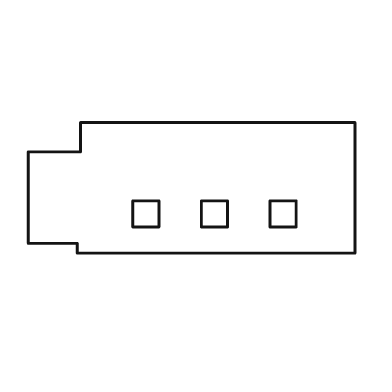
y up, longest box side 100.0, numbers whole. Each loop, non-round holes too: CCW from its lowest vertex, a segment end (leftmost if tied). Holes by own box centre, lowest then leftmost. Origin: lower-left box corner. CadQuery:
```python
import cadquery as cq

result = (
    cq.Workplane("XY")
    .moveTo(15.0, 0.0)
    .lineTo(100.0, 0.0)
    .lineTo(100.0, 40.0)
    .lineTo(16.0, 40.0)
    .lineTo(16.0, 31.0)
    .lineTo(0.0, 31.0)
    .lineTo(0.0, 3.0)
    .lineTo(15.0, 3.0)
    .close()
    .moveTo(32.0, 8.0)
    .lineTo(40.0, 8.0)
    .lineTo(40.0, 16.0)
    .lineTo(32.0, 16.0)
    .close()
    .moveTo(53.0, 8.0)
    .lineTo(61.0, 8.0)
    .lineTo(61.0, 16.0)
    .lineTo(53.0, 16.0)
    .close()
    .moveTo(74.0, 8.0)
    .lineTo(82.0, 8.0)
    .lineTo(82.0, 16.0)
    .lineTo(74.0, 16.0)
    .close()
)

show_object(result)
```